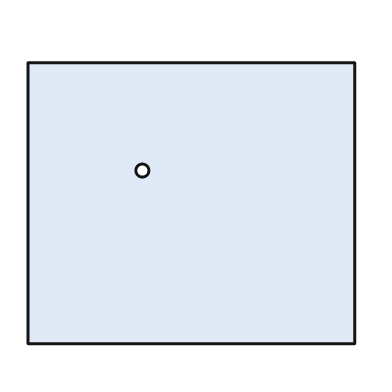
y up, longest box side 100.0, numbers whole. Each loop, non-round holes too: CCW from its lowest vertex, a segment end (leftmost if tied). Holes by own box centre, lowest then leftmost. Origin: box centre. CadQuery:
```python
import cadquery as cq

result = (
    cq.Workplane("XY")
    .moveTo(-50.0, -43.0)
    .lineTo(50.0, -43.0)
    .lineTo(50.0, 43.0)
    .lineTo(-50.0, 43.0)
    .close()
    .moveTo(-15.0, 10.0)
    .circle(2.0)
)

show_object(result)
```